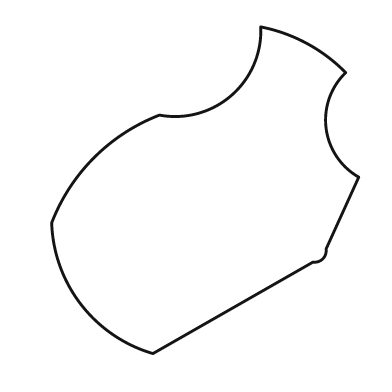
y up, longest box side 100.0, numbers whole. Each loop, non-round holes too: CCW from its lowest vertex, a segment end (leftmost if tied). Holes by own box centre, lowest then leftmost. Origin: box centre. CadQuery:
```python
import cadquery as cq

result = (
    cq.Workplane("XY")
    .moveTo(-16.0, -50.0)
    .lineTo(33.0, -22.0)
    .threePointArc((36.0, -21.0), (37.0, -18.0))
    .lineTo(47.0, 4.0)
    .threePointArc((37.0, 19.0), (43.0, 36.0))
    .threePointArc((31.0, 45.0), (17.0, 50.0))
    .threePointArc((8.0, 29.0), (-14.0, 23.0))
    .threePointArc((-34.0, 10.0), (-47.0, -10.0))
    .threePointArc((-38.0, -35.0), (-16.0, -50.0))
    .close()
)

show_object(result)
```